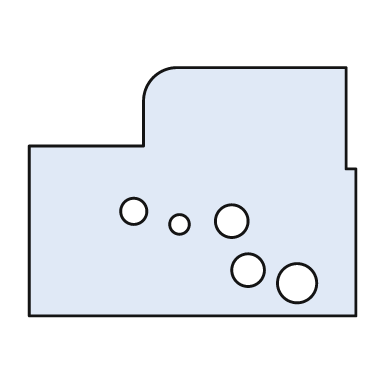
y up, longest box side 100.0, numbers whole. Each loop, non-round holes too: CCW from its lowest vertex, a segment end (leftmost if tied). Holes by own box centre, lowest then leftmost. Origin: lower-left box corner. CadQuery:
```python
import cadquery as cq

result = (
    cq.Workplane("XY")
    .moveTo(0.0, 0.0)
    .lineTo(100.0, 0.0)
    .lineTo(100.0, 45.0)
    .lineTo(97.0, 45.0)
    .lineTo(97.0, 76.0)
    .lineTo(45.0, 76.0)
    .threePointArc((38.0, 73.0), (35.0, 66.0))
    .lineTo(35.0, 52.0)
    .lineTo(0.0, 52.0)
    .close()
    .moveTo(82.0, 10.0)
    .circle(6.0)
    .moveTo(67.0, 14.0)
    .circle(5.0)
    .moveTo(46.0, 28.0)
    .circle(3.0)
    .moveTo(62.0, 29.0)
    .circle(5.0)
    .moveTo(32.0, 32.0)
    .circle(4.0)
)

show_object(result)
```